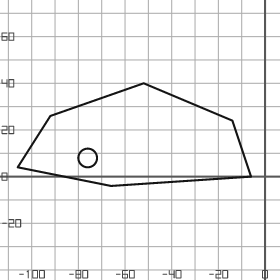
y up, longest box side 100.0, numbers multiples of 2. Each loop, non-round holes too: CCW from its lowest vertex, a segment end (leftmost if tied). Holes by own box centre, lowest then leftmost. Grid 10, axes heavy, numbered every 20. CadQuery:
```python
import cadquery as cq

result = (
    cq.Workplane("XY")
    .moveTo(-66.0, -4.0)
    .lineTo(-6.0, 0.0)
    .lineTo(-14.0, 24.0)
    .lineTo(-52.0, 40.0)
    .lineTo(-92.0, 26.0)
    .lineTo(-106.0, 4.0)
    .close()
    .moveTo(-76.0, 8.0)
    .circle(4.0)
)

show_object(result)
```